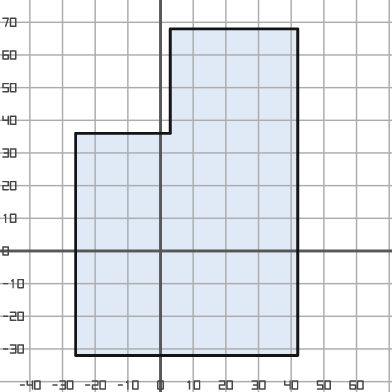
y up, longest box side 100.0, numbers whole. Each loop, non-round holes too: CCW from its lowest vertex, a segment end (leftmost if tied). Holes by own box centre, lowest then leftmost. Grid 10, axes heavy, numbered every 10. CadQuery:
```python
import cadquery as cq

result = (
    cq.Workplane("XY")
    .moveTo(-26.0, -32.0)
    .lineTo(42.0, -32.0)
    .lineTo(42.0, 68.0)
    .lineTo(3.0, 68.0)
    .lineTo(3.0, 36.0)
    .lineTo(-26.0, 36.0)
    .close()
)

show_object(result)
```